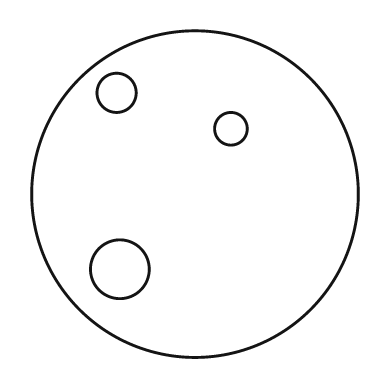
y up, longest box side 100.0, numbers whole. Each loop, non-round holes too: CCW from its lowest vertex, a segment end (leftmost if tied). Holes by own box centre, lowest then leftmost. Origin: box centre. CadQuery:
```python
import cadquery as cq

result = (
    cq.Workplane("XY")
    .moveTo(0.0, 0.0)
    .circle(50.0)
    .moveTo(-23.0, -23.0)
    .circle(9.0)
    .moveTo(11.0, 20.0)
    .circle(5.0)
    .moveTo(-24.0, 31.0)
    .circle(6.0)
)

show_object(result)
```